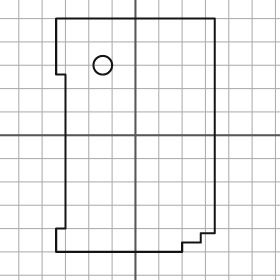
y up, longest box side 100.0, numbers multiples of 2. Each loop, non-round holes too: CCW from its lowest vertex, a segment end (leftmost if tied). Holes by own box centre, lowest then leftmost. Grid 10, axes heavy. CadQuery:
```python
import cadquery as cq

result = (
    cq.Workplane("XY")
    .moveTo(-34.0, -50.0)
    .lineTo(20.0, -50.0)
    .lineTo(20.0, -46.0)
    .lineTo(28.0, -46.0)
    .lineTo(28.0, -42.0)
    .lineTo(34.0, -42.0)
    .lineTo(34.0, 50.0)
    .lineTo(-34.0, 50.0)
    .lineTo(-34.0, 26.0)
    .lineTo(-30.0, 26.0)
    .lineTo(-30.0, -40.0)
    .lineTo(-34.0, -40.0)
    .close()
    .moveTo(-14.0, 30.0)
    .circle(4.0)
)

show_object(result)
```